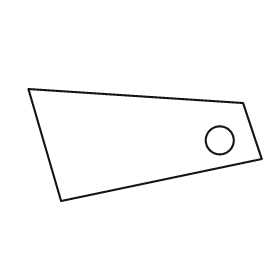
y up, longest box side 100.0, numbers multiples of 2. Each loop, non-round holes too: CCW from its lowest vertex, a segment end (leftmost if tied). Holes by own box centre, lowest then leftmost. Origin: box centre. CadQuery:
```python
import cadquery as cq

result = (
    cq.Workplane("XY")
    .moveTo(-36.0, -24.0)
    .lineTo(50.0, -6.0)
    .lineTo(42.0, 18.0)
    .lineTo(-50.0, 24.0)
    .close()
    .moveTo(32.0, 2.0)
    .circle(6.0)
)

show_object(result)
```